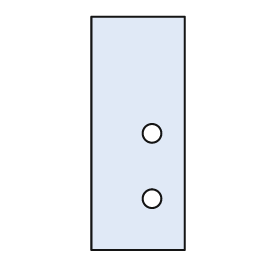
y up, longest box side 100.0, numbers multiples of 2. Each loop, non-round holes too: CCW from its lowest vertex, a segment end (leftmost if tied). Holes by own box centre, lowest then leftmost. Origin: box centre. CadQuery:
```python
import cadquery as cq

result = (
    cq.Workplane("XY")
    .moveTo(-20.0, -50.0)
    .lineTo(20.0, -50.0)
    .lineTo(20.0, 50.0)
    .lineTo(-20.0, 50.0)
    .close()
    .moveTo(6.0, -28.0)
    .circle(4.0)
    .moveTo(6.0, 0.0)
    .circle(4.0)
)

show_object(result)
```